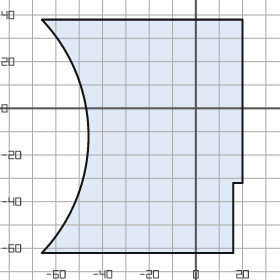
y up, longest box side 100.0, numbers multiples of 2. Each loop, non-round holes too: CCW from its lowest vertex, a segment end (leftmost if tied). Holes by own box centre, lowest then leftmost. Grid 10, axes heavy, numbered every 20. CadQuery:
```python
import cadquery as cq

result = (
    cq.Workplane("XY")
    .moveTo(-66.0, -62.0)
    .lineTo(16.0, -62.0)
    .lineTo(16.0, -32.0)
    .lineTo(20.0, -32.0)
    .lineTo(20.0, 38.0)
    .lineTo(-66.0, 38.0)
    .threePointArc((-46.0, -12.0), (-66.0, -62.0))
    .close()
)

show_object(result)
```